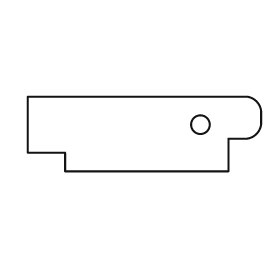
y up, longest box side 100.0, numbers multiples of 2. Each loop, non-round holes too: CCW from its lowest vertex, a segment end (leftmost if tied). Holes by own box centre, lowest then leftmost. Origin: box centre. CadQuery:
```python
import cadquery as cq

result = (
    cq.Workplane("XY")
    .moveTo(-34.0, -16.0)
    .lineTo(36.0, -16.0)
    .lineTo(36.0, -2.0)
    .lineTo(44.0, -2.0)
    .threePointArc((48.0, 0.0), (50.0, 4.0))
    .lineTo(50.0, 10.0)
    .threePointArc((48.0, 14.0), (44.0, 16.0))
    .lineTo(-50.0, 16.0)
    .lineTo(-50.0, -8.0)
    .lineTo(-34.0, -8.0)
    .close()
    .moveTo(24.0, 4.0)
    .circle(4.0)
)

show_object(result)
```